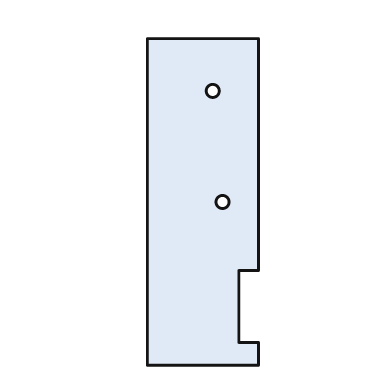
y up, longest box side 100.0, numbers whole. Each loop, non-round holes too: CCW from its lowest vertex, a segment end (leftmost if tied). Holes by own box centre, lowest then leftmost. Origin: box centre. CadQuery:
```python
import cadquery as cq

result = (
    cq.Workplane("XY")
    .moveTo(-17.0, -50.0)
    .lineTo(17.0, -50.0)
    .lineTo(17.0, -43.0)
    .lineTo(11.0, -43.0)
    .lineTo(11.0, -21.0)
    .lineTo(17.0, -21.0)
    .lineTo(17.0, 50.0)
    .lineTo(-17.0, 50.0)
    .close()
    .moveTo(6.0, 0.0)
    .circle(2.0)
    .moveTo(3.0, 34.0)
    .circle(2.0)
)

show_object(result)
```